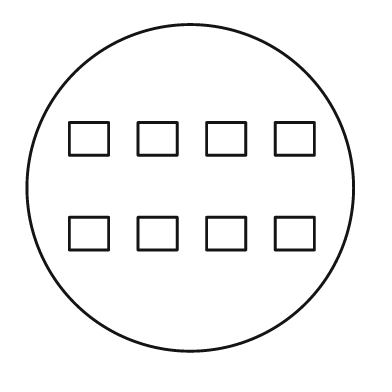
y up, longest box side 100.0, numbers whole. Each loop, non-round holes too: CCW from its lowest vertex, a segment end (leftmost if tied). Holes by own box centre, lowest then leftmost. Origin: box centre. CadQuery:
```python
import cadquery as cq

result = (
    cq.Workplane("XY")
    .moveTo(0.0, 0.0)
    .circle(50.0)
    .moveTo(-37.0, -19.0)
    .lineTo(-25.0, -19.0)
    .lineTo(-25.0, -9.0)
    .lineTo(-37.0, -9.0)
    .close()
    .moveTo(-16.0, -19.0)
    .lineTo(-4.0, -19.0)
    .lineTo(-4.0, -9.0)
    .lineTo(-16.0, -9.0)
    .close()
    .moveTo(5.0, -19.0)
    .lineTo(17.0, -19.0)
    .lineTo(17.0, -9.0)
    .lineTo(5.0, -9.0)
    .close()
    .moveTo(26.0, -19.0)
    .lineTo(38.0, -19.0)
    .lineTo(38.0, -9.0)
    .lineTo(26.0, -9.0)
    .close()
    .moveTo(-37.0, 10.0)
    .lineTo(-25.0, 10.0)
    .lineTo(-25.0, 20.0)
    .lineTo(-37.0, 20.0)
    .close()
    .moveTo(-16.0, 10.0)
    .lineTo(-4.0, 10.0)
    .lineTo(-4.0, 20.0)
    .lineTo(-16.0, 20.0)
    .close()
    .moveTo(5.0, 10.0)
    .lineTo(17.0, 10.0)
    .lineTo(17.0, 20.0)
    .lineTo(5.0, 20.0)
    .close()
    .moveTo(26.0, 10.0)
    .lineTo(38.0, 10.0)
    .lineTo(38.0, 20.0)
    .lineTo(26.0, 20.0)
    .close()
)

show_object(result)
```